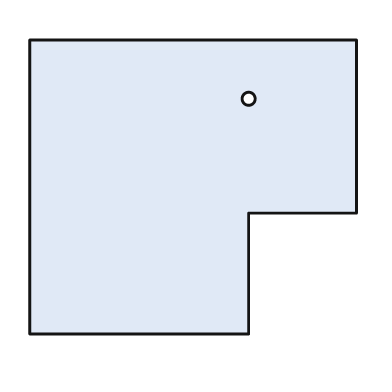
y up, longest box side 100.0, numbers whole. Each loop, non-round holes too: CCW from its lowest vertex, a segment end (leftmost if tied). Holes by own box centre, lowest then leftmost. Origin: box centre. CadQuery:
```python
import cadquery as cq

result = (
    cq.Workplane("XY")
    .moveTo(-50.0, -45.0)
    .lineTo(17.0, -45.0)
    .lineTo(17.0, -8.0)
    .lineTo(50.0, -8.0)
    .lineTo(50.0, 45.0)
    .lineTo(-50.0, 45.0)
    .close()
    .moveTo(17.0, 27.0)
    .circle(2.0)
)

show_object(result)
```